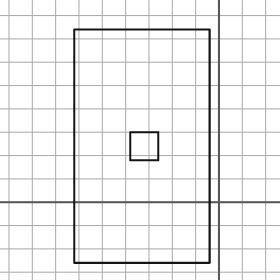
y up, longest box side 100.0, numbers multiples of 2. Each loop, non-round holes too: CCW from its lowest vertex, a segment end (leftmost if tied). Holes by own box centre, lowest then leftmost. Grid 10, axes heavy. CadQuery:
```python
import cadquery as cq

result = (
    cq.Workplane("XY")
    .moveTo(-62.0, -26.0)
    .lineTo(-4.0, -26.0)
    .lineTo(-4.0, 74.0)
    .lineTo(-62.0, 74.0)
    .close()
    .moveTo(-38.0, 18.0)
    .lineTo(-26.0, 18.0)
    .lineTo(-26.0, 30.0)
    .lineTo(-38.0, 30.0)
    .close()
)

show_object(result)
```